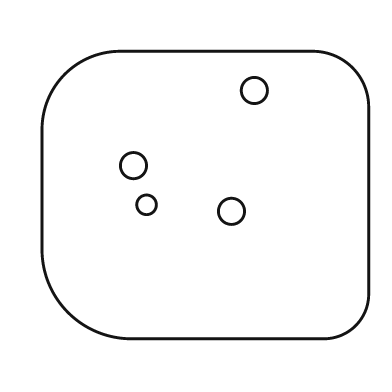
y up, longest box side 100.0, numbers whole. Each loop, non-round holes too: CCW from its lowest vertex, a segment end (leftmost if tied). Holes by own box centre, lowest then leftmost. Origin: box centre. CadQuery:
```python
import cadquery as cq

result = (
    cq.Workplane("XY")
    .moveTo(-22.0, -44.0)
    .lineTo(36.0, -44.0)
    .threePointArc((46.0, -40.0), (50.0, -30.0))
    .lineTo(50.0, 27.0)
    .threePointArc((45.0, 39.0), (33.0, 44.0))
    .lineTo(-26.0, 44.0)
    .threePointArc((-43.0, 37.0), (-50.0, 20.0))
    .lineTo(-50.0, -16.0)
    .threePointArc((-42.0, -36.0), (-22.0, -44.0))
    .close()
    .moveTo(8.0, -5.0)
    .circle(4.0)
    .moveTo(-18.0, -3.0)
    .circle(3.0)
    .moveTo(-22.0, 9.0)
    .circle(4.0)
    .moveTo(15.0, 32.0)
    .circle(4.0)
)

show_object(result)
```